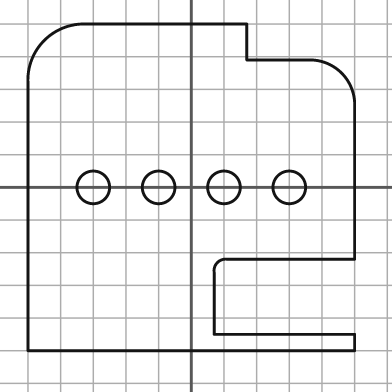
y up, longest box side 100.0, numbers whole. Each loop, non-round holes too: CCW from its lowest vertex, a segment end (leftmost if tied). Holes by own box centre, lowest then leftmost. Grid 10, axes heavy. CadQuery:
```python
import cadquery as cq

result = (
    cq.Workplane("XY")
    .moveTo(-50.0, -50.0)
    .lineTo(50.0, -50.0)
    .lineTo(50.0, -45.0)
    .lineTo(7.0, -45.0)
    .lineTo(7.0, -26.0)
    .threePointArc((8.0, -23.0), (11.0, -22.0))
    .lineTo(50.0, -22.0)
    .lineTo(50.0, 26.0)
    .threePointArc((46.0, 35.0), (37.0, 39.0))
    .lineTo(17.0, 39.0)
    .lineTo(17.0, 50.0)
    .lineTo(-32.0, 50.0)
    .threePointArc((-45.0, 45.0), (-50.0, 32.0))
    .close()
    .moveTo(-30.0, 0.0)
    .circle(5.0)
    .moveTo(-10.0, 0.0)
    .circle(5.0)
    .moveTo(10.0, 0.0)
    .circle(5.0)
    .moveTo(30.0, 0.0)
    .circle(5.0)
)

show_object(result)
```